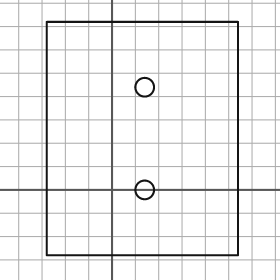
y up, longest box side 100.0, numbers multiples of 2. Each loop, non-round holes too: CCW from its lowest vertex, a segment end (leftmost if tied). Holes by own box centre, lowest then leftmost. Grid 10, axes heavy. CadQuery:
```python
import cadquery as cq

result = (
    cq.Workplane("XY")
    .moveTo(-28.0, -28.0)
    .lineTo(54.0, -28.0)
    .lineTo(54.0, 72.0)
    .lineTo(-28.0, 72.0)
    .close()
    .moveTo(14.0, 0.0)
    .circle(4.0)
    .moveTo(14.0, 44.0)
    .circle(4.0)
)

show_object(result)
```